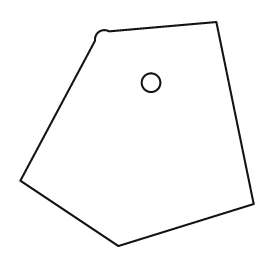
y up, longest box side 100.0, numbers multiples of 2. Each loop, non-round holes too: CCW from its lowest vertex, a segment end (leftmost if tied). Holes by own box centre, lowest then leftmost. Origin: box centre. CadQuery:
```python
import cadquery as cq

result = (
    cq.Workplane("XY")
    .moveTo(-8.0, -48.0)
    .lineTo(50.0, -30.0)
    .lineTo(34.0, 48.0)
    .lineTo(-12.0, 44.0)
    .threePointArc((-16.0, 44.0), (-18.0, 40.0))
    .lineTo(-50.0, -20.0)
    .close()
    .moveTo(6.0, 22.0)
    .circle(4.0)
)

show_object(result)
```